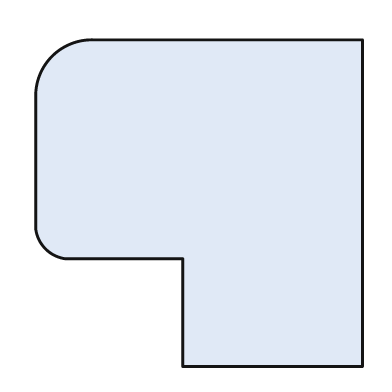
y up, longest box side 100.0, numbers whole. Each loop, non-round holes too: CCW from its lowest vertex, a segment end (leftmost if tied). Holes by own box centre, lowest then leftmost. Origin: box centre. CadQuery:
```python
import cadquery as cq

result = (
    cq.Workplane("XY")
    .moveTo(-5.0, -50.0)
    .lineTo(50.0, -50.0)
    .lineTo(50.0, 50.0)
    .lineTo(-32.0, 50.0)
    .threePointArc((-45.0, 45.0), (-50.0, 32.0))
    .lineTo(-50.0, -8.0)
    .threePointArc((-47.0, -14.0), (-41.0, -17.0))
    .lineTo(-5.0, -17.0)
    .close()
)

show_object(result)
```